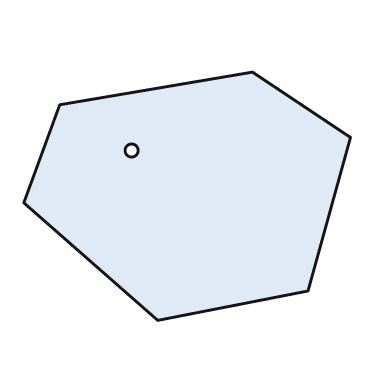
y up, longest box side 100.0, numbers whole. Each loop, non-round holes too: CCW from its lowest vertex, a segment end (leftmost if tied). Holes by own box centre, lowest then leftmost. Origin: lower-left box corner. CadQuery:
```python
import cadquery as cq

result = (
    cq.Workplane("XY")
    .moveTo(41.0, 0.0)
    .lineTo(87.0, 9.0)
    .lineTo(100.0, 56.0)
    .lineTo(70.0, 76.0)
    .lineTo(11.0, 66.0)
    .lineTo(0.0, 36.0)
    .close()
    .moveTo(33.0, 52.0)
    .circle(2.0)
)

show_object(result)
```